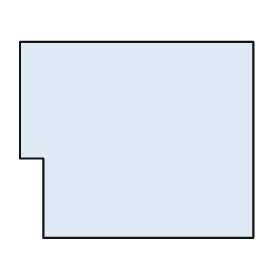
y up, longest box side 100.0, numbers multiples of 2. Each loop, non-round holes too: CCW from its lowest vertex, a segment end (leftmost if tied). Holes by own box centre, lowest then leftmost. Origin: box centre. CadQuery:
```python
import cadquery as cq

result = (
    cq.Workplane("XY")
    .moveTo(-40.0, -42.0)
    .lineTo(50.0, -42.0)
    .lineTo(50.0, 42.0)
    .lineTo(-50.0, 42.0)
    .lineTo(-50.0, -8.0)
    .lineTo(-40.0, -8.0)
    .close()
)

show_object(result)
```